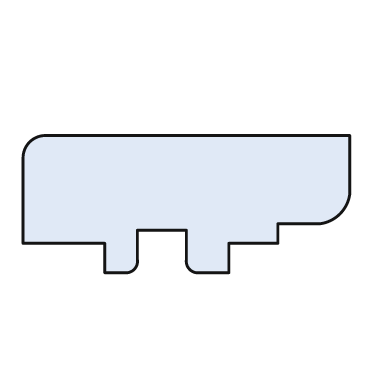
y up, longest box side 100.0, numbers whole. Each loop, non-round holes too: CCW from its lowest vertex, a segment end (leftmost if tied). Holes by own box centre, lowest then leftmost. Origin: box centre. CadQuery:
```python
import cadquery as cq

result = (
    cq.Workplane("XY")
    .moveTo(-25.0, -21.0)
    .lineTo(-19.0, -21.0)
    .threePointArc((-16.0, -20.0), (-15.0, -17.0))
    .lineTo(-15.0, -8.0)
    .lineTo(0.0, -8.0)
    .lineTo(0.0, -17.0)
    .threePointArc((1.0, -20.0), (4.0, -21.0))
    .lineTo(13.0, -21.0)
    .lineTo(13.0, -12.0)
    .lineTo(28.0, -12.0)
    .lineTo(28.0, -6.0)
    .lineTo(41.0, -6.0)
    .threePointArc((47.0, -3.0), (50.0, 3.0))
    .lineTo(50.0, 21.0)
    .lineTo(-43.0, 21.0)
    .threePointArc((-48.0, 19.0), (-50.0, 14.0))
    .lineTo(-50.0, -12.0)
    .lineTo(-25.0, -12.0)
    .close()
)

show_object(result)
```